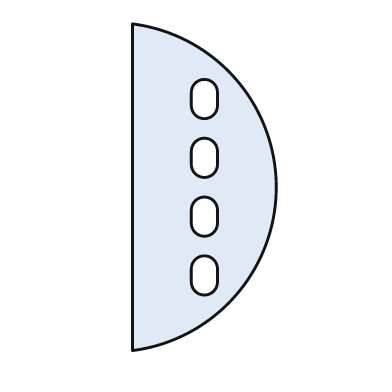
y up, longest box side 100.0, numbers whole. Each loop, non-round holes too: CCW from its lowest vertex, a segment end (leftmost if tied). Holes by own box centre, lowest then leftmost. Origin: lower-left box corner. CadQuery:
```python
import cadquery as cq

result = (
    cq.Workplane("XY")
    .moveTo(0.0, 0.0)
    .threePointArc((44.0, 50.0), (0.0, 100.0))
    .close()
    .moveTo(18.0, 21.0)
    .threePointArc((22.0, 17.0), (26.0, 21.0))
    .lineTo(26.0, 25.0)
    .threePointArc((22.0, 29.0), (18.0, 25.0))
    .close()
    .moveTo(18.0, 39.0)
    .threePointArc((22.0, 35.0), (26.0, 39.0))
    .lineTo(26.0, 43.0)
    .threePointArc((22.0, 47.0), (18.0, 43.0))
    .close()
    .moveTo(18.0, 57.0)
    .threePointArc((22.0, 53.0), (26.0, 57.0))
    .lineTo(26.0, 61.0)
    .threePointArc((22.0, 65.0), (18.0, 61.0))
    .close()
    .moveTo(18.0, 75.0)
    .threePointArc((22.0, 71.0), (26.0, 75.0))
    .lineTo(26.0, 79.0)
    .threePointArc((22.0, 83.0), (18.0, 79.0))
    .close()
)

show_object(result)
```